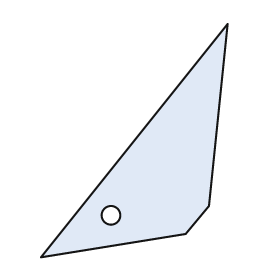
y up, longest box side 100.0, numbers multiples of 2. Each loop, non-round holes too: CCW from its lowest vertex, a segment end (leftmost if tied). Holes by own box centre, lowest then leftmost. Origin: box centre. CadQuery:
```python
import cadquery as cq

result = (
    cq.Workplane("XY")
    .moveTo(-40.0, -50.0)
    .lineTo(22.0, -40.0)
    .lineTo(32.0, -28.0)
    .lineTo(40.0, 50.0)
    .close()
    .moveTo(-10.0, -32.0)
    .circle(4.0)
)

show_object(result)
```